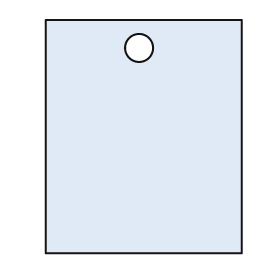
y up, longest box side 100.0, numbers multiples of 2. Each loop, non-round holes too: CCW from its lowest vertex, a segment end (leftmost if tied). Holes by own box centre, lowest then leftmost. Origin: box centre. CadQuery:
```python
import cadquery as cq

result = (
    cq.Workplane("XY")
    .moveTo(-42.0, -50.0)
    .lineTo(42.0, -50.0)
    .lineTo(42.0, 50.0)
    .lineTo(-42.0, 50.0)
    .close()
    .moveTo(-2.0, 38.0)
    .circle(6.0)
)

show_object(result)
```